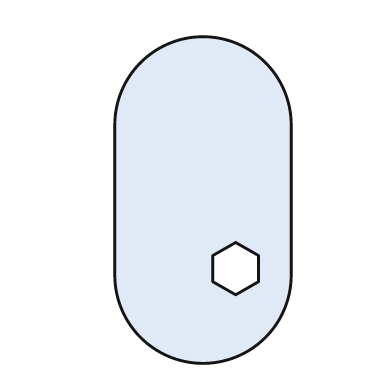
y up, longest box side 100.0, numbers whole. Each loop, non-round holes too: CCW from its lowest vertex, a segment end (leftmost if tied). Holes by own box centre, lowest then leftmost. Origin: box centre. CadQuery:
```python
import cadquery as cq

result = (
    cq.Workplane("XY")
    .moveTo(-27.0, -23.0)
    .threePointArc((0.0, -50.0), (27.0, -23.0))
    .lineTo(27.0, 23.0)
    .threePointArc((0.0, 50.0), (-27.0, 23.0))
    .close()
    .moveTo(10.0, -29.0)
    .lineTo(17.0, -25.0)
    .lineTo(17.0, -17.0)
    .lineTo(10.0, -13.0)
    .lineTo(3.0, -17.0)
    .lineTo(3.0, -25.0)
    .close()
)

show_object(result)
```